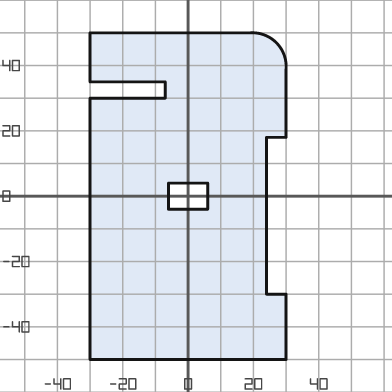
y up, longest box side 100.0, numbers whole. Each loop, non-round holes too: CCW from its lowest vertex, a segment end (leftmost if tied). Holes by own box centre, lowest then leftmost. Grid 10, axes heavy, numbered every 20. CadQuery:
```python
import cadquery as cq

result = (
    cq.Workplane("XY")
    .moveTo(-30.0, -50.0)
    .lineTo(30.0, -50.0)
    .lineTo(30.0, -30.0)
    .lineTo(24.0, -30.0)
    .lineTo(24.0, 18.0)
    .lineTo(30.0, 18.0)
    .lineTo(30.0, 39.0)
    .threePointArc((27.0, 47.0), (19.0, 50.0))
    .lineTo(-30.0, 50.0)
    .lineTo(-30.0, 35.0)
    .lineTo(-7.0, 35.0)
    .lineTo(-7.0, 30.0)
    .lineTo(-30.0, 30.0)
    .close()
    .moveTo(-6.0, -4.0)
    .lineTo(6.0, -4.0)
    .lineTo(6.0, 4.0)
    .lineTo(-6.0, 4.0)
    .close()
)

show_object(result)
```